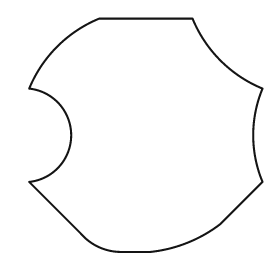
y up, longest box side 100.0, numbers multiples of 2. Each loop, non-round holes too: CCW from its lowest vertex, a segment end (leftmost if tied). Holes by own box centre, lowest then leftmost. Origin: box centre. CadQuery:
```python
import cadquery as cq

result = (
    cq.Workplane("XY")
    .moveTo(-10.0, -50.0)
    .lineTo(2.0, -50.0)
    .threePointArc((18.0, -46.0), (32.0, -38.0))
    .lineTo(50.0, -20.0)
    .threePointArc((46.0, 0.0), (50.0, 20.0))
    .threePointArc((32.0, 32.0), (20.0, 50.0))
    .lineTo(-20.0, 50.0)
    .threePointArc((-38.0, 38.0), (-50.0, 20.0))
    .threePointArc((-32.0, 0.0), (-50.0, -20.0))
    .lineTo(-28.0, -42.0)
    .threePointArc((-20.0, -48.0), (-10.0, -50.0))
    .close()
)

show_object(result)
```